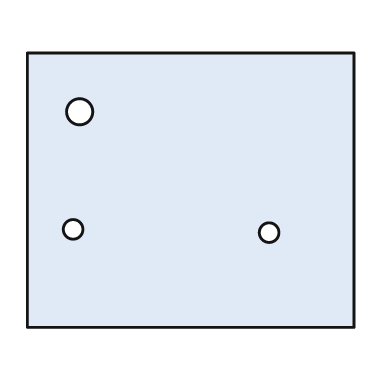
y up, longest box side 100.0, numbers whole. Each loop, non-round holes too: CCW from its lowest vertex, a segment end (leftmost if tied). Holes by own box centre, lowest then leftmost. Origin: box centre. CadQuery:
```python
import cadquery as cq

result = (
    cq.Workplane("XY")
    .moveTo(-50.0, -42.0)
    .lineTo(50.0, -42.0)
    .lineTo(50.0, 42.0)
    .lineTo(-50.0, 42.0)
    .close()
    .moveTo(24.0, -13.0)
    .circle(3.0)
    .moveTo(-36.0, -12.0)
    .circle(3.0)
    .moveTo(-34.0, 24.0)
    .circle(4.0)
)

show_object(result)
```